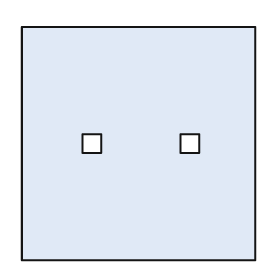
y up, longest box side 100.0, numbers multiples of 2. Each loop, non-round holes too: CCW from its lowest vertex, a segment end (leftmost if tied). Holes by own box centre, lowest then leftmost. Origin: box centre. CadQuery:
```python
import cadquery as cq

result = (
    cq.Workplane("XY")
    .moveTo(-50.0, -50.0)
    .lineTo(50.0, -50.0)
    .lineTo(50.0, 50.0)
    .lineTo(-50.0, 50.0)
    .close()
    .moveTo(-24.0, -4.0)
    .lineTo(-16.0, -4.0)
    .lineTo(-16.0, 4.0)
    .lineTo(-24.0, 4.0)
    .close()
    .moveTo(18.0, -4.0)
    .lineTo(26.0, -4.0)
    .lineTo(26.0, 4.0)
    .lineTo(18.0, 4.0)
    .close()
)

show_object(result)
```